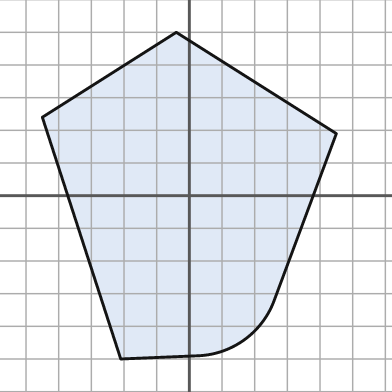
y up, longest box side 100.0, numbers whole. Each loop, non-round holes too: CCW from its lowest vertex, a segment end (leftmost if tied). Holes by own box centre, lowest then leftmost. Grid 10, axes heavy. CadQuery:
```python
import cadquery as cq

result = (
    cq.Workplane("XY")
    .moveTo(-21.0, -50.0)
    .lineTo(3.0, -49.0)
    .threePointArc((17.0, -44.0), (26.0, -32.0))
    .lineTo(45.0, 19.0)
    .lineTo(-4.0, 50.0)
    .lineTo(-45.0, 24.0)
    .close()
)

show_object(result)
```